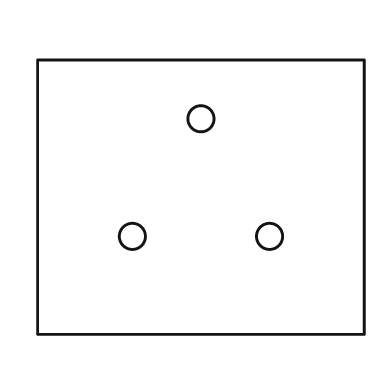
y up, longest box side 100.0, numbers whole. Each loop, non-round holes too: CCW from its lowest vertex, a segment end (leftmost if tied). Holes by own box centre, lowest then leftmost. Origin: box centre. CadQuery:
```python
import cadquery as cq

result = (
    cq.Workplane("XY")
    .moveTo(-50.0, -42.0)
    .lineTo(50.0, -42.0)
    .lineTo(50.0, 42.0)
    .lineTo(-50.0, 42.0)
    .close()
    .moveTo(-21.0, -12.0)
    .circle(4.0)
    .moveTo(21.0, -12.0)
    .circle(4.0)
    .moveTo(0.0, 24.0)
    .circle(4.0)
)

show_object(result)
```